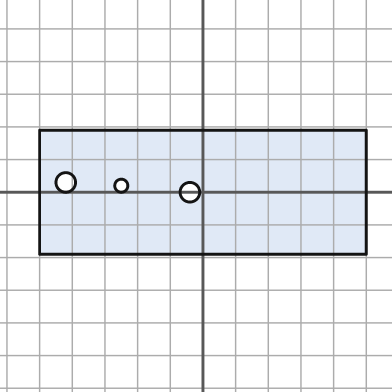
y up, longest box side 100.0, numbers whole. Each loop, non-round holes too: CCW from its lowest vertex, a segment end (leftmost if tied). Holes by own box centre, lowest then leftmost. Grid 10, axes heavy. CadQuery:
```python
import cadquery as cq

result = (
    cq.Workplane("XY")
    .moveTo(-50.0, -19.0)
    .lineTo(50.0, -19.0)
    .lineTo(50.0, 19.0)
    .lineTo(-50.0, 19.0)
    .close()
    .moveTo(-4.0, 0.0)
    .circle(3.0)
    .moveTo(-25.0, 2.0)
    .circle(2.0)
    .moveTo(-42.0, 3.0)
    .circle(3.0)
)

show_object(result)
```